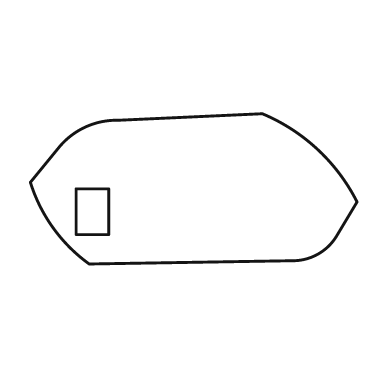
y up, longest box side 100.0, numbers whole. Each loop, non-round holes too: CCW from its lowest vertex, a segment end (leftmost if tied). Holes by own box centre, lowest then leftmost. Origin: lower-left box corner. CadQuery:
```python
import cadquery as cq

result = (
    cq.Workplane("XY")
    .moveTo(18.0, 0.0)
    .lineTo(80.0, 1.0)
    .threePointArc((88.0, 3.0), (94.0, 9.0))
    .lineTo(100.0, 19.0)
    .threePointArc((88.0, 35.0), (71.0, 46.0))
    .lineTo(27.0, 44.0)
    .threePointArc((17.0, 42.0), (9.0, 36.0))
    .lineTo(0.0, 25.0)
    .threePointArc((7.0, 11.0), (18.0, 0.0))
    .close()
    .moveTo(14.0, 9.0)
    .lineTo(24.0, 9.0)
    .lineTo(24.0, 23.0)
    .lineTo(14.0, 23.0)
    .close()
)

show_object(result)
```